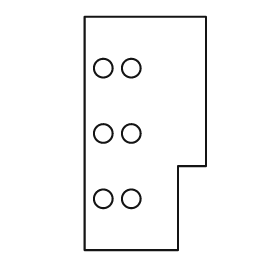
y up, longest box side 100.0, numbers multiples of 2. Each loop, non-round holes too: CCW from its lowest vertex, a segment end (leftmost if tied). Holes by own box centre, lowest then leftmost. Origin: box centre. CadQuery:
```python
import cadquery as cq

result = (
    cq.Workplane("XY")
    .moveTo(-26.0, -50.0)
    .lineTo(14.0, -50.0)
    .lineTo(14.0, -14.0)
    .lineTo(26.0, -14.0)
    .lineTo(26.0, 50.0)
    .lineTo(-26.0, 50.0)
    .close()
    .moveTo(-18.0, -28.0)
    .circle(4.0)
    .moveTo(-6.0, -28.0)
    .circle(4.0)
    .moveTo(-18.0, 0.0)
    .circle(4.0)
    .moveTo(-6.0, 0.0)
    .circle(4.0)
    .moveTo(-18.0, 28.0)
    .circle(4.0)
    .moveTo(-6.0, 28.0)
    .circle(4.0)
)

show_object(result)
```